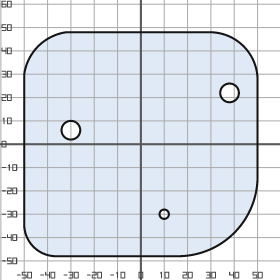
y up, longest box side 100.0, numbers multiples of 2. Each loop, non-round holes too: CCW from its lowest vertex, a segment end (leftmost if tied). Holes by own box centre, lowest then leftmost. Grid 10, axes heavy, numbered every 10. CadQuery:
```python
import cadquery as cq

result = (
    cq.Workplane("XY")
    .moveTo(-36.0, -48.0)
    .lineTo(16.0, -48.0)
    .threePointArc((40.0, -38.0), (50.0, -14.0))
    .lineTo(50.0, 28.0)
    .threePointArc((44.0, 42.0), (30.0, 48.0))
    .lineTo(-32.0, 48.0)
    .threePointArc((-44.0, 42.0), (-50.0, 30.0))
    .lineTo(-50.0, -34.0)
    .threePointArc((-46.0, -44.0), (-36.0, -48.0))
    .close()
    .moveTo(10.0, -30.0)
    .circle(2.0)
    .moveTo(-30.0, 6.0)
    .circle(4.0)
    .moveTo(38.0, 22.0)
    .circle(4.0)
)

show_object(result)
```